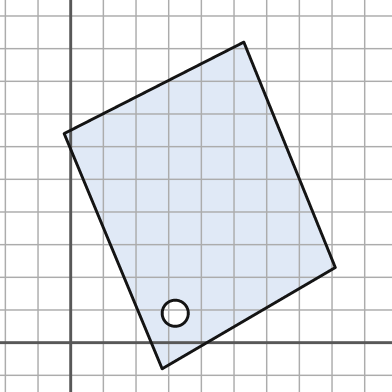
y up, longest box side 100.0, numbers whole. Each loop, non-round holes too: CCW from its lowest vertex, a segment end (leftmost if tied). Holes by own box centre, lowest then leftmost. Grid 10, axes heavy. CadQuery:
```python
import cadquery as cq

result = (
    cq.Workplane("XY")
    .moveTo(28.0, -8.0)
    .lineTo(81.0, 23.0)
    .lineTo(53.0, 92.0)
    .lineTo(-2.0, 64.0)
    .close()
    .moveTo(32.0, 9.0)
    .circle(4.0)
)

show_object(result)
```